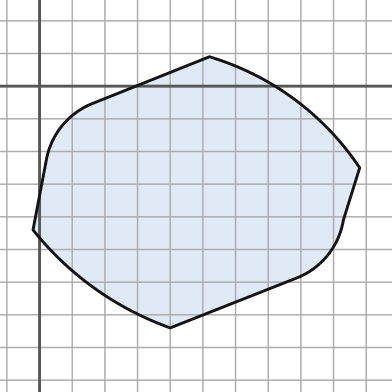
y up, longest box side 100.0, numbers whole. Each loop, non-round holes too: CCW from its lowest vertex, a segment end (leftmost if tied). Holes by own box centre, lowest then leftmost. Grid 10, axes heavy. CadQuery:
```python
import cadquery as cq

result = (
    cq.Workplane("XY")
    .moveTo(40.0, -74.0)
    .lineTo(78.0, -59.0)
    .threePointArc((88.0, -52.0), (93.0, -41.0))
    .lineTo(98.0, -25.0)
    .threePointArc((78.0, -4.0), (52.0, 9.0))
    .lineTo(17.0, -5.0)
    .threePointArc((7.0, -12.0), (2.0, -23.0))
    .lineTo(-2.0, -44.0)
    .threePointArc((17.0, -62.0), (40.0, -74.0))
    .close()
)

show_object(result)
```